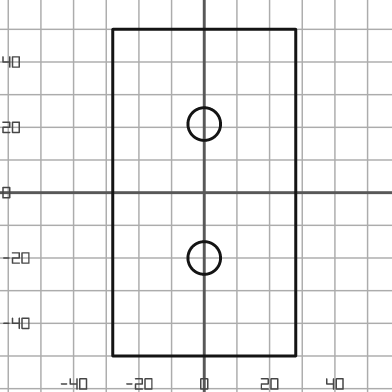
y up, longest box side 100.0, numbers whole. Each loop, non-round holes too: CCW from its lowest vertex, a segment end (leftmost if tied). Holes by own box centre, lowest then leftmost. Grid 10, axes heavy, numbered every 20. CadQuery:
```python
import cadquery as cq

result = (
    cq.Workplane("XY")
    .moveTo(-28.0, -50.0)
    .lineTo(28.0, -50.0)
    .lineTo(28.0, 50.0)
    .lineTo(-28.0, 50.0)
    .close()
    .moveTo(0.0, -20.0)
    .circle(5.0)
    .moveTo(0.0, 21.0)
    .circle(5.0)
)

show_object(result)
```